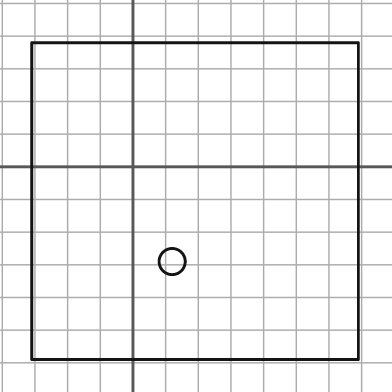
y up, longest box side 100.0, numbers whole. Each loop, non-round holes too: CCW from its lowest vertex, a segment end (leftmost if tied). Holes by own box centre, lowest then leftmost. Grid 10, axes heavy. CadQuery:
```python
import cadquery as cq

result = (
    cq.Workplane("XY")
    .moveTo(-31.0, -59.0)
    .lineTo(69.0, -59.0)
    .lineTo(69.0, 38.0)
    .lineTo(-31.0, 38.0)
    .close()
    .moveTo(12.0, -29.0)
    .circle(4.0)
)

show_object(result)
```